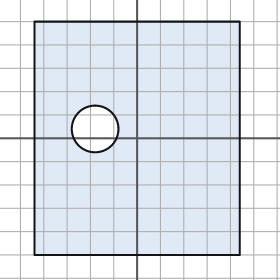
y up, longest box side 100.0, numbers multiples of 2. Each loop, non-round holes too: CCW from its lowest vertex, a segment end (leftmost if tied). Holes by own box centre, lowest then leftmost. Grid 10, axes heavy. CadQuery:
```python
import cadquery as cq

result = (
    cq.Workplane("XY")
    .moveTo(-44.0, -50.0)
    .lineTo(44.0, -50.0)
    .lineTo(44.0, 50.0)
    .lineTo(-44.0, 50.0)
    .close()
    .moveTo(-18.0, 4.0)
    .circle(10.0)
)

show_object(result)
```